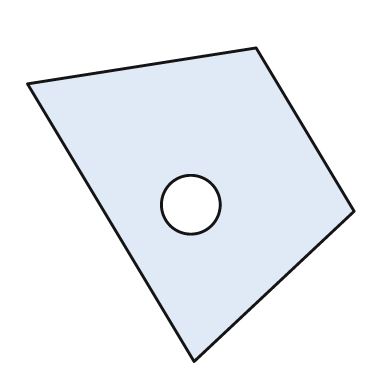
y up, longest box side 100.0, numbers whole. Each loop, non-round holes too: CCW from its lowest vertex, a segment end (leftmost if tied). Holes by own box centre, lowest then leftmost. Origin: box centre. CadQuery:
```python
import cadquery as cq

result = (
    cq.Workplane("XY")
    .moveTo(1.0, -48.0)
    .lineTo(50.0, -2.0)
    .lineTo(20.0, 48.0)
    .lineTo(-50.0, 37.0)
    .close()
    .moveTo(0.0, 0.0)
    .circle(9.0)
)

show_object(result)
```